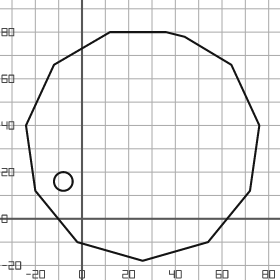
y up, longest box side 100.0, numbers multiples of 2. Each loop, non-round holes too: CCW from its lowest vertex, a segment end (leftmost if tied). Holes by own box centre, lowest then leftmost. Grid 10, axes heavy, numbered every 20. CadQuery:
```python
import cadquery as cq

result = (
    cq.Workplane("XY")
    .moveTo(26.0, -18.0)
    .lineTo(54.0, -10.0)
    .lineTo(72.0, 12.0)
    .lineTo(76.0, 40.0)
    .lineTo(64.0, 66.0)
    .lineTo(44.0, 78.0)
    .lineTo(36.0, 80.0)
    .lineTo(12.0, 80.0)
    .lineTo(-12.0, 66.0)
    .lineTo(-24.0, 40.0)
    .lineTo(-20.0, 12.0)
    .lineTo(-2.0, -10.0)
    .close()
    .moveTo(-8.0, 16.0)
    .circle(4.0)
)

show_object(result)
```